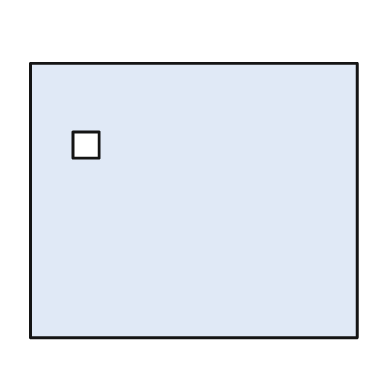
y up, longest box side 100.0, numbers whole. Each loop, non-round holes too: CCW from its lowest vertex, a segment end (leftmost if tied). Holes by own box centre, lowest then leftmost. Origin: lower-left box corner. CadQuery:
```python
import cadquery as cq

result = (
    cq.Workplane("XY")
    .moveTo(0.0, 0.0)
    .lineTo(100.0, 0.0)
    .lineTo(100.0, 84.0)
    .lineTo(0.0, 84.0)
    .close()
    .moveTo(13.0, 55.0)
    .lineTo(21.0, 55.0)
    .lineTo(21.0, 63.0)
    .lineTo(13.0, 63.0)
    .close()
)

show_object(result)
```